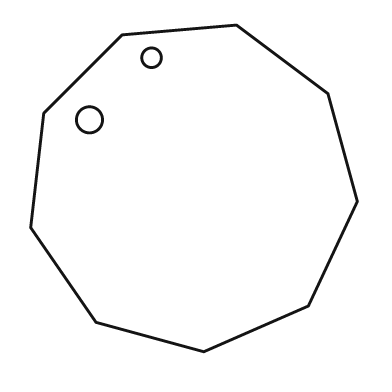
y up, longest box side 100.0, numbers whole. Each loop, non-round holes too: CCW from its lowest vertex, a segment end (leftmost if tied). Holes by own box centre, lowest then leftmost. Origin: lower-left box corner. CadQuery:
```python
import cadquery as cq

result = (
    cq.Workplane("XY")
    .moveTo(53.0, 0.0)
    .lineTo(85.0, 14.0)
    .lineTo(100.0, 46.0)
    .lineTo(91.0, 79.0)
    .lineTo(63.0, 100.0)
    .lineTo(28.0, 97.0)
    .lineTo(4.0, 73.0)
    .lineTo(0.0, 38.0)
    .lineTo(20.0, 9.0)
    .close()
    .moveTo(18.0, 71.0)
    .circle(4.0)
    .moveTo(37.0, 90.0)
    .circle(3.0)
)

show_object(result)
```